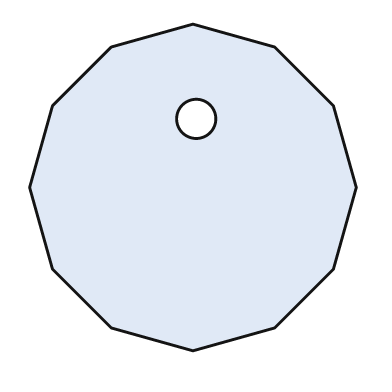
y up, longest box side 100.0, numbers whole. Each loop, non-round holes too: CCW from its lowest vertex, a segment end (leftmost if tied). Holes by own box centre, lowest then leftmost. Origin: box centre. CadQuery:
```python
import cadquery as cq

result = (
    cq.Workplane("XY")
    .moveTo(0.0, -50.0)
    .lineTo(25.0, -43.0)
    .lineTo(43.0, -25.0)
    .lineTo(50.0, 0.0)
    .lineTo(43.0, 25.0)
    .lineTo(25.0, 43.0)
    .lineTo(0.0, 50.0)
    .lineTo(-25.0, 43.0)
    .lineTo(-43.0, 25.0)
    .lineTo(-50.0, 0.0)
    .lineTo(-43.0, -25.0)
    .lineTo(-25.0, -43.0)
    .close()
    .moveTo(1.0, 21.0)
    .circle(6.0)
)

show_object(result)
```